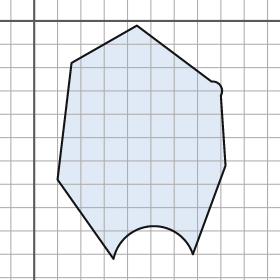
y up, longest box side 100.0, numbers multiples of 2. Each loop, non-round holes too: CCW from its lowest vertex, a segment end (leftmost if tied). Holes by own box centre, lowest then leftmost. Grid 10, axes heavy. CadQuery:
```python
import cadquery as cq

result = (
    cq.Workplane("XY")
    .moveTo(34.0, -102.0)
    .threePointArc((50.0, -88.0), (68.0, -100.0))
    .lineTo(82.0, -62.0)
    .lineTo(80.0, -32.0)
    .threePointArc((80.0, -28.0), (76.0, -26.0))
    .lineTo(44.0, -2.0)
    .lineTo(16.0, -18.0)
    .lineTo(10.0, -68.0)
    .close()
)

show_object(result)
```